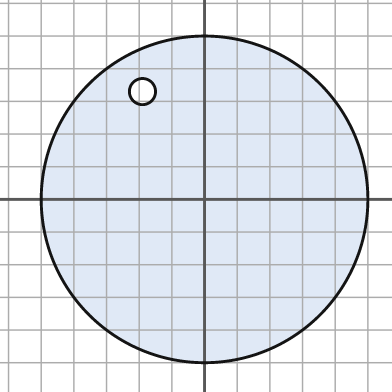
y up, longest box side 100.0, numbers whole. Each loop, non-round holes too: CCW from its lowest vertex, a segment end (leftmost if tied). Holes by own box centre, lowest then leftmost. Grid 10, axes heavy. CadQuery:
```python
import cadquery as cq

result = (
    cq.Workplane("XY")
    .moveTo(0.0, 0.0)
    .circle(50.0)
    .moveTo(-19.0, 33.0)
    .circle(4.0)
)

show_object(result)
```